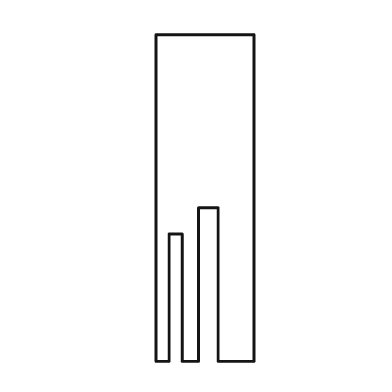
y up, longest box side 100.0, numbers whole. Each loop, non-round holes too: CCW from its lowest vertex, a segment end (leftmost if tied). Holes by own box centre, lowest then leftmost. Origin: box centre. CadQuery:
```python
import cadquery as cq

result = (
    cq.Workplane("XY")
    .moveTo(-15.0, -50.0)
    .lineTo(-11.0, -50.0)
    .lineTo(-11.0, -11.0)
    .lineTo(-7.0, -11.0)
    .lineTo(-7.0, -50.0)
    .lineTo(-2.0, -50.0)
    .lineTo(-2.0, -3.0)
    .lineTo(4.0, -3.0)
    .lineTo(4.0, -50.0)
    .lineTo(15.0, -50.0)
    .lineTo(15.0, 50.0)
    .lineTo(-15.0, 50.0)
    .close()
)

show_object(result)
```